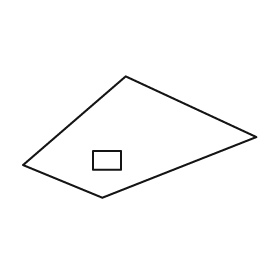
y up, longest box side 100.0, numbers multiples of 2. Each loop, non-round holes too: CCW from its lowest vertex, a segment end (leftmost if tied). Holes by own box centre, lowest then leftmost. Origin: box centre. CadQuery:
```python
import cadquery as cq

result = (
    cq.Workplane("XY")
    .moveTo(-16.0, -26.0)
    .lineTo(50.0, 0.0)
    .lineTo(-6.0, 26.0)
    .lineTo(-50.0, -12.0)
    .close()
    .moveTo(-20.0, -14.0)
    .lineTo(-8.0, -14.0)
    .lineTo(-8.0, -6.0)
    .lineTo(-20.0, -6.0)
    .close()
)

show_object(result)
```